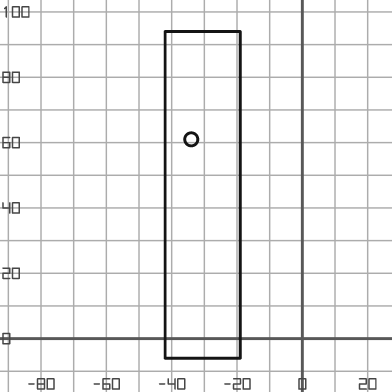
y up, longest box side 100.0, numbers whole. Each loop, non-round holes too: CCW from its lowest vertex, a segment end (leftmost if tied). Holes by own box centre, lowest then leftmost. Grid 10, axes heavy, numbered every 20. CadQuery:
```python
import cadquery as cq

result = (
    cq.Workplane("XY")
    .moveTo(-42.0, -6.0)
    .lineTo(-19.0, -6.0)
    .lineTo(-19.0, 94.0)
    .lineTo(-42.0, 94.0)
    .close()
    .moveTo(-34.0, 61.0)
    .circle(2.0)
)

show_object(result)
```